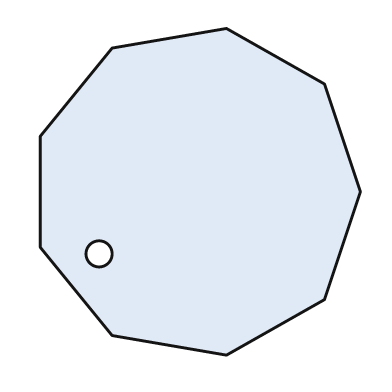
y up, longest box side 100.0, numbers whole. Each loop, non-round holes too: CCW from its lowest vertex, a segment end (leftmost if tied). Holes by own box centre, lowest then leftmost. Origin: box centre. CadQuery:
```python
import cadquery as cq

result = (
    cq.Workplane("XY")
    .moveTo(8.0, -50.0)
    .lineTo(38.0, -33.0)
    .lineTo(49.0, 0.0)
    .lineTo(38.0, 33.0)
    .lineTo(8.0, 50.0)
    .lineTo(-27.0, 44.0)
    .lineTo(-49.0, 17.0)
    .lineTo(-49.0, -17.0)
    .lineTo(-27.0, -44.0)
    .close()
    .moveTo(-31.0, -19.0)
    .circle(4.0)
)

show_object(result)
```